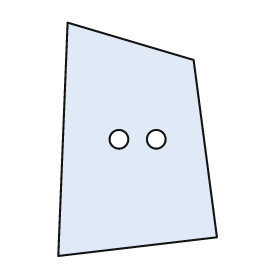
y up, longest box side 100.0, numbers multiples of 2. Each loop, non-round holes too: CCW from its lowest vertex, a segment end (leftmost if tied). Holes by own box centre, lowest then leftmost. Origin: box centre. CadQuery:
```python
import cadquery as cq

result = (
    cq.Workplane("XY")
    .moveTo(-34.0, -50.0)
    .lineTo(34.0, -42.0)
    .lineTo(24.0, 34.0)
    .lineTo(-30.0, 50.0)
    .close()
    .moveTo(-8.0, 0.0)
    .circle(4.0)
    .moveTo(8.0, 0.0)
    .circle(4.0)
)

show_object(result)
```